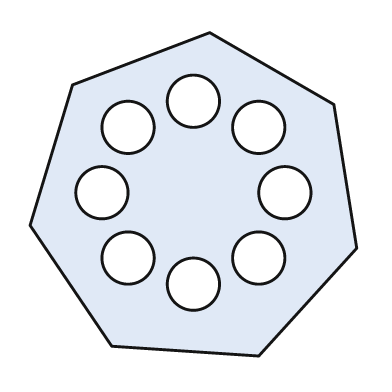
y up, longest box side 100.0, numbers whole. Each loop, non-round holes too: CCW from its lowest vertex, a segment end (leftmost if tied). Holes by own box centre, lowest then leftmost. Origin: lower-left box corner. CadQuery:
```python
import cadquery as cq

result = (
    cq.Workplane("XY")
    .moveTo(70.0, 0.0)
    .lineTo(100.0, 33.0)
    .lineTo(93.0, 77.0)
    .lineTo(55.0, 99.0)
    .lineTo(13.0, 83.0)
    .lineTo(0.0, 40.0)
    .lineTo(25.0, 3.0)
    .close()
    .moveTo(50.0, 22.0)
    .circle(8.0)
    .moveTo(30.0, 30.0)
    .circle(8.0)
    .moveTo(70.0, 30.0)
    .circle(8.0)
    .moveTo(22.0, 50.0)
    .circle(8.0)
    .moveTo(78.0, 50.0)
    .circle(8.0)
    .moveTo(30.0, 70.0)
    .circle(8.0)
    .moveTo(70.0, 70.0)
    .circle(8.0)
    .moveTo(50.0, 78.0)
    .circle(8.0)
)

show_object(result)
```